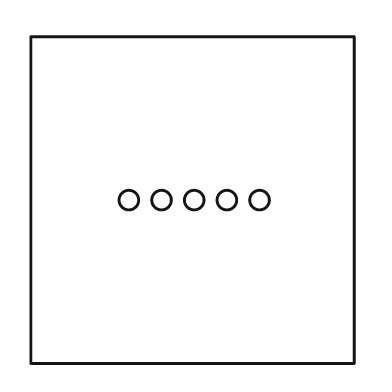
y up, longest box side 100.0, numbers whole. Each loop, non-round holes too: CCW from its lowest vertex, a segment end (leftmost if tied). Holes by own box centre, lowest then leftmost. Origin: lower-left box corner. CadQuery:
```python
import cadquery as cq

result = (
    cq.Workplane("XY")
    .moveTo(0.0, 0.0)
    .lineTo(99.0, 0.0)
    .lineTo(99.0, 100.0)
    .lineTo(0.0, 100.0)
    .close()
    .moveTo(30.0, 50.0)
    .circle(3.0)
    .moveTo(40.0, 50.0)
    .circle(3.0)
    .moveTo(50.0, 50.0)
    .circle(3.0)
    .moveTo(60.0, 50.0)
    .circle(3.0)
    .moveTo(70.0, 50.0)
    .circle(3.0)
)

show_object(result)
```